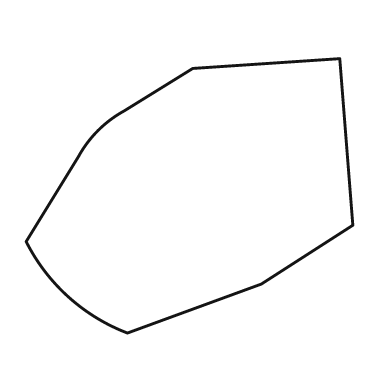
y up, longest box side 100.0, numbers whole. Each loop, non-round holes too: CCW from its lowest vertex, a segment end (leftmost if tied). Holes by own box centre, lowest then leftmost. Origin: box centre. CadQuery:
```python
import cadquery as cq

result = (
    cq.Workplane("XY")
    .moveTo(-19.0, -42.0)
    .lineTo(22.0, -27.0)
    .lineTo(50.0, -9.0)
    .lineTo(46.0, 42.0)
    .lineTo(1.0, 39.0)
    .lineTo(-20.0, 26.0)
    .threePointArc((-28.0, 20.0), (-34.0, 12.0))
    .lineTo(-50.0, -14.0)
    .threePointArc((-37.0, -31.0), (-19.0, -42.0))
    .close()
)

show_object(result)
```